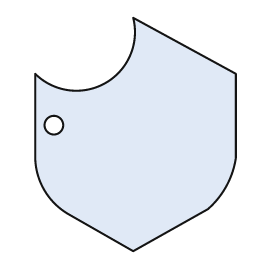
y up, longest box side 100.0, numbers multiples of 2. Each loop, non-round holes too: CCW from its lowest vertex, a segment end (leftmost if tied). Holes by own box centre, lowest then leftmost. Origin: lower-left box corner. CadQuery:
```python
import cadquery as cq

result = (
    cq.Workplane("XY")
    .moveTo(42.0, 0.0)
    .lineTo(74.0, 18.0)
    .threePointArc((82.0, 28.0), (86.0, 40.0))
    .lineTo(86.0, 76.0)
    .lineTo(42.0, 100.0)
    .threePointArc((30.0, 72.0), (0.0, 76.0))
    .lineTo(0.0, 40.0)
    .threePointArc((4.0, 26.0), (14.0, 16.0))
    .close()
    .moveTo(8.0, 54.0)
    .circle(4.0)
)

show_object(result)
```